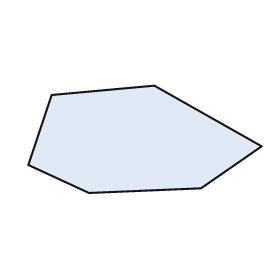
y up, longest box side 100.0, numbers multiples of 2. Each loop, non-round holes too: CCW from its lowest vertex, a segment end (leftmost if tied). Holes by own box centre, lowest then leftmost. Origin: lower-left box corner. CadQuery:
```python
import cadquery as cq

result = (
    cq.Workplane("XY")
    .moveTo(26.0, 0.0)
    .lineTo(74.0, 2.0)
    .lineTo(100.0, 20.0)
    .lineTo(54.0, 46.0)
    .lineTo(10.0, 42.0)
    .lineTo(0.0, 12.0)
    .close()
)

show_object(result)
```